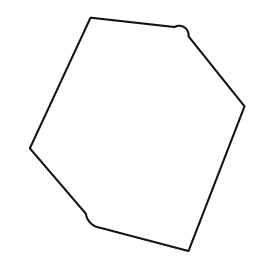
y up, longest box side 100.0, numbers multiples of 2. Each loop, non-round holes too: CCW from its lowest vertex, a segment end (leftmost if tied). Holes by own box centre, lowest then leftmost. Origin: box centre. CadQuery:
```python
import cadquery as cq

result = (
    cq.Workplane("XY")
    .moveTo(22.0, -50.0)
    .lineTo(46.0, 12.0)
    .lineTo(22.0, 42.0)
    .threePointArc((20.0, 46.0), (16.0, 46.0))
    .lineTo(-20.0, 50.0)
    .lineTo(-46.0, -6.0)
    .lineTo(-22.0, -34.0)
    .threePointArc((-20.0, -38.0), (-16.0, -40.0))
    .close()
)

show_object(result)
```